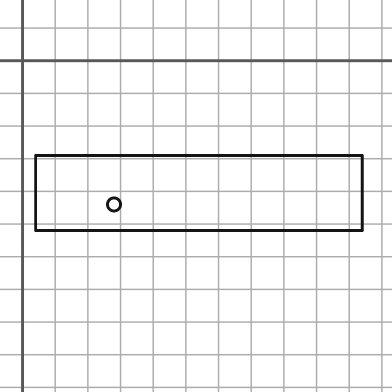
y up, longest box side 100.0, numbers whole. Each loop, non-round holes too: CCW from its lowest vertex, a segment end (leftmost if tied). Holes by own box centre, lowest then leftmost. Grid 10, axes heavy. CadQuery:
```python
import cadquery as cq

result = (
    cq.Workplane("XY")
    .moveTo(4.0, -52.0)
    .lineTo(104.0, -52.0)
    .lineTo(104.0, -29.0)
    .lineTo(4.0, -29.0)
    .close()
    .moveTo(28.0, -44.0)
    .circle(2.0)
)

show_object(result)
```